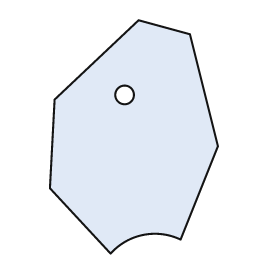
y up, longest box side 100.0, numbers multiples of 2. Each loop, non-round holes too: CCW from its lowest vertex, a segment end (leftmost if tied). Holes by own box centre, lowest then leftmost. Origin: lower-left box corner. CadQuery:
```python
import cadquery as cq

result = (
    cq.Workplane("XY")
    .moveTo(26.0, 0.0)
    .threePointArc((40.0, 8.0), (56.0, 6.0))
    .lineTo(72.0, 46.0)
    .lineTo(60.0, 94.0)
    .lineTo(38.0, 100.0)
    .lineTo(2.0, 66.0)
    .lineTo(0.0, 28.0)
    .close()
    .moveTo(32.0, 68.0)
    .circle(4.0)
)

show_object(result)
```